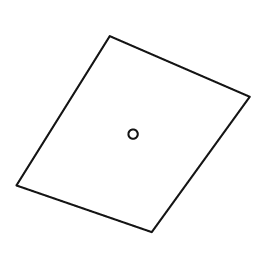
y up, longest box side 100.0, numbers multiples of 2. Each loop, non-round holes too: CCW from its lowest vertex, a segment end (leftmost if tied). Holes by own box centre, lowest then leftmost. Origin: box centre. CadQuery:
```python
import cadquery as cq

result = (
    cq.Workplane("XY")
    .moveTo(8.0, -42.0)
    .lineTo(50.0, 16.0)
    .lineTo(-10.0, 42.0)
    .lineTo(-50.0, -22.0)
    .close()
    .moveTo(0.0, 0.0)
    .circle(2.0)
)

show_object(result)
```